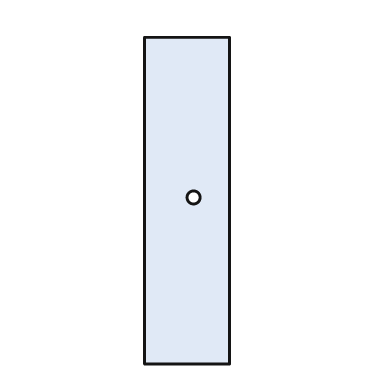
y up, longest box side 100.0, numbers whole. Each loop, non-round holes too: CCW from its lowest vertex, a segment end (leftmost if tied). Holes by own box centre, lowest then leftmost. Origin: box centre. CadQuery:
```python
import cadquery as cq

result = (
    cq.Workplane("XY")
    .moveTo(-13.0, -50.0)
    .lineTo(13.0, -50.0)
    .lineTo(13.0, 50.0)
    .lineTo(-13.0, 50.0)
    .close()
    .moveTo(2.0, 1.0)
    .circle(2.0)
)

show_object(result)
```